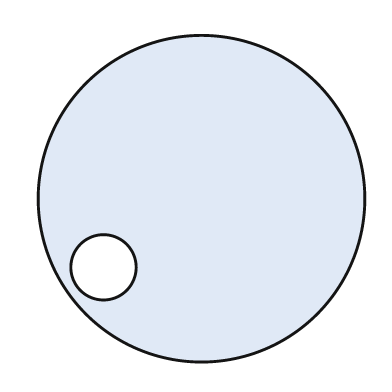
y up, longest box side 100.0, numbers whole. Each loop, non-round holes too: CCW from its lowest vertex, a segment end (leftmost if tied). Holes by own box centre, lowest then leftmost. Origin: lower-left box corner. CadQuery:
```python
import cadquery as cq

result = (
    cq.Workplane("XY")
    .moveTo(50.0, 50.0)
    .circle(50.0)
    .moveTo(20.0, 29.0)
    .circle(10.0)
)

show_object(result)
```